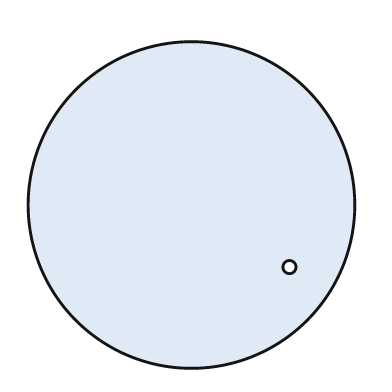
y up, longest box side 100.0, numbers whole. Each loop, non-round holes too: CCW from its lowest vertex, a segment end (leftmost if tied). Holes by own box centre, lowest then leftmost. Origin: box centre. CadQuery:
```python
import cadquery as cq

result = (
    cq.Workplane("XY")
    .moveTo(0.0, 0.0)
    .circle(50.0)
    .moveTo(30.0, -19.0)
    .circle(2.0)
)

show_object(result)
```